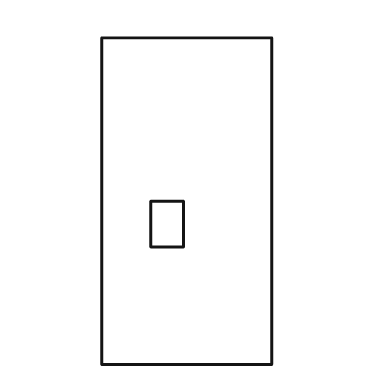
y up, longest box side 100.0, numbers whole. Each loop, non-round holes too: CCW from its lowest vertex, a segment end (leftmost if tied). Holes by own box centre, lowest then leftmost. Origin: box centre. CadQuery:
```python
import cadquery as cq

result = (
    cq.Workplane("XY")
    .moveTo(-26.0, -50.0)
    .lineTo(26.0, -50.0)
    .lineTo(26.0, 50.0)
    .lineTo(-26.0, 50.0)
    .close()
    .moveTo(-11.0, -14.0)
    .lineTo(-1.0, -14.0)
    .lineTo(-1.0, 0.0)
    .lineTo(-11.0, 0.0)
    .close()
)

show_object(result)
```